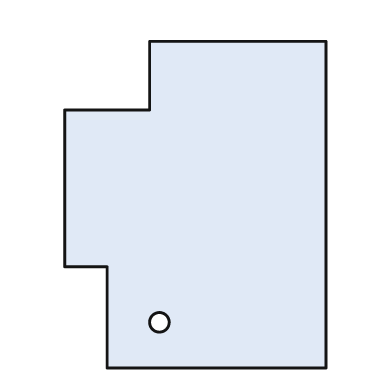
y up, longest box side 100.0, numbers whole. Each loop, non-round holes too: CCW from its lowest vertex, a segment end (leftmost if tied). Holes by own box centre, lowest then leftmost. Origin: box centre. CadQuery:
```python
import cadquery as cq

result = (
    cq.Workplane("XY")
    .moveTo(-27.0, -50.0)
    .lineTo(40.0, -50.0)
    .lineTo(40.0, 50.0)
    .lineTo(-14.0, 50.0)
    .lineTo(-14.0, 29.0)
    .lineTo(-40.0, 29.0)
    .lineTo(-40.0, -19.0)
    .lineTo(-27.0, -19.0)
    .close()
    .moveTo(-11.0, -36.0)
    .circle(3.0)
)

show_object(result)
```